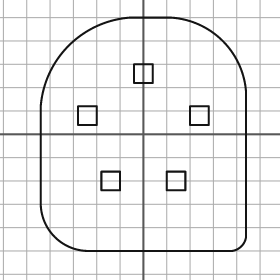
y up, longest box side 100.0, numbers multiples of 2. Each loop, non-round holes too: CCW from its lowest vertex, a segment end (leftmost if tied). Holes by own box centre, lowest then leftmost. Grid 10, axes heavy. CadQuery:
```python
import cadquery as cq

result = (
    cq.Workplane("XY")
    .moveTo(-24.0, -50.0)
    .lineTo(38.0, -50.0)
    .threePointArc((42.0, -48.0), (44.0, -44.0))
    .lineTo(44.0, 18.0)
    .threePointArc((34.0, 40.0), (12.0, 50.0))
    .lineTo(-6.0, 50.0)
    .threePointArc((-32.0, 38.0), (-44.0, 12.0))
    .lineTo(-44.0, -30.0)
    .threePointArc((-38.0, -44.0), (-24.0, -50.0))
    .close()
    .moveTo(-18.0, -24.0)
    .lineTo(-10.0, -24.0)
    .lineTo(-10.0, -16.0)
    .lineTo(-18.0, -16.0)
    .close()
    .moveTo(10.0, -24.0)
    .lineTo(18.0, -24.0)
    .lineTo(18.0, -16.0)
    .lineTo(10.0, -16.0)
    .close()
    .moveTo(-28.0, 4.0)
    .lineTo(-20.0, 4.0)
    .lineTo(-20.0, 12.0)
    .lineTo(-28.0, 12.0)
    .close()
    .moveTo(20.0, 4.0)
    .lineTo(28.0, 4.0)
    .lineTo(28.0, 12.0)
    .lineTo(20.0, 12.0)
    .close()
    .moveTo(-4.0, 22.0)
    .lineTo(4.0, 22.0)
    .lineTo(4.0, 30.0)
    .lineTo(-4.0, 30.0)
    .close()
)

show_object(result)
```